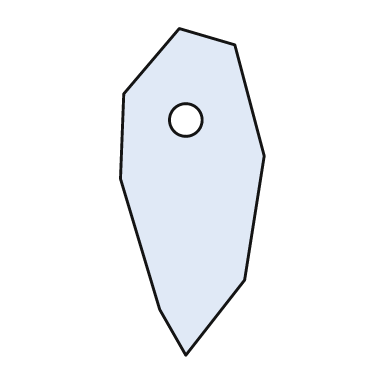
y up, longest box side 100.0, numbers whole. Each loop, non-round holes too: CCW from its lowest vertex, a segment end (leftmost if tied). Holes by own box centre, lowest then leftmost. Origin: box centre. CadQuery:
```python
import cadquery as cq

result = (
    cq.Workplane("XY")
    .moveTo(-2.0, -50.0)
    .lineTo(16.0, -27.0)
    .lineTo(22.0, 11.0)
    .lineTo(13.0, 45.0)
    .lineTo(-4.0, 50.0)
    .lineTo(-21.0, 30.0)
    .lineTo(-22.0, 4.0)
    .lineTo(-10.0, -36.0)
    .close()
    .moveTo(-2.0, 22.0)
    .circle(5.0)
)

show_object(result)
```